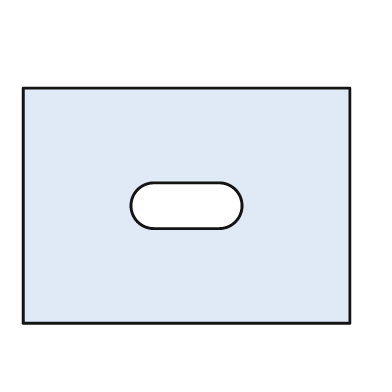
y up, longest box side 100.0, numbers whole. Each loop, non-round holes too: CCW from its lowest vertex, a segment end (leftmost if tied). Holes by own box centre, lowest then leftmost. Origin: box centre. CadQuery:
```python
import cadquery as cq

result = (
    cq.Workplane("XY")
    .moveTo(-50.0, -36.0)
    .lineTo(50.0, -36.0)
    .lineTo(50.0, 36.0)
    .lineTo(-50.0, 36.0)
    .close()
    .moveTo(-10.0, -7.0)
    .lineTo(10.0, -7.0)
    .threePointArc((17.0, 0.0), (10.0, 7.0))
    .lineTo(-10.0, 7.0)
    .threePointArc((-17.0, 0.0), (-10.0, -7.0))
    .close()
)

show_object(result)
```